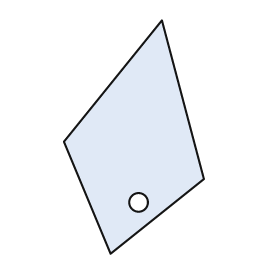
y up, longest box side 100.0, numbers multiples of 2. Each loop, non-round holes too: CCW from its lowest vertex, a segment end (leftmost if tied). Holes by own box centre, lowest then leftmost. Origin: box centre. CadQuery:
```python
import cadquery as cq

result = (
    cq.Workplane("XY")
    .moveTo(-10.0, -50.0)
    .lineTo(30.0, -18.0)
    .lineTo(12.0, 50.0)
    .lineTo(-30.0, -2.0)
    .close()
    .moveTo(2.0, -28.0)
    .circle(4.0)
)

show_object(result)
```